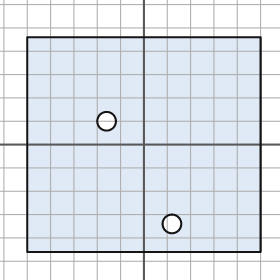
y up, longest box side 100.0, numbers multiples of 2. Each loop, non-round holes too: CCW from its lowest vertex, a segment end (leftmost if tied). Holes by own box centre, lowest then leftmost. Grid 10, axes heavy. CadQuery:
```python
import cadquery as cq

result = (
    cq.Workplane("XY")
    .moveTo(-50.0, -46.0)
    .lineTo(50.0, -46.0)
    .lineTo(50.0, 46.0)
    .lineTo(-50.0, 46.0)
    .close()
    .moveTo(12.0, -34.0)
    .circle(4.0)
    .moveTo(-16.0, 10.0)
    .circle(4.0)
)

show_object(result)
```